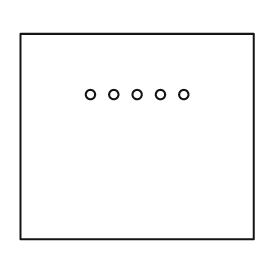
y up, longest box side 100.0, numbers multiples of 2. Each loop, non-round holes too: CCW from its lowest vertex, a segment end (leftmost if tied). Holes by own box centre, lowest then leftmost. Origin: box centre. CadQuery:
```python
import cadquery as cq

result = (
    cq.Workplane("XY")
    .moveTo(-50.0, -44.0)
    .lineTo(50.0, -44.0)
    .lineTo(50.0, 44.0)
    .lineTo(-50.0, 44.0)
    .close()
    .moveTo(-20.0, 18.0)
    .circle(2.0)
    .moveTo(-10.0, 18.0)
    .circle(2.0)
    .moveTo(0.0, 18.0)
    .circle(2.0)
    .moveTo(10.0, 18.0)
    .circle(2.0)
    .moveTo(20.0, 18.0)
    .circle(2.0)
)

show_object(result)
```